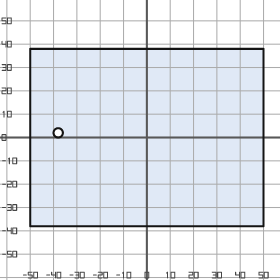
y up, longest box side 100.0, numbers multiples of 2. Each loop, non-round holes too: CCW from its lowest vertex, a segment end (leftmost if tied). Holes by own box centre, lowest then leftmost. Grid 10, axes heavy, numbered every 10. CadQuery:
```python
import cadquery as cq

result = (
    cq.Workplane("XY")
    .moveTo(-50.0, -38.0)
    .lineTo(50.0, -38.0)
    .lineTo(50.0, 38.0)
    .lineTo(-50.0, 38.0)
    .close()
    .moveTo(-38.0, 2.0)
    .circle(2.0)
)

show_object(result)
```